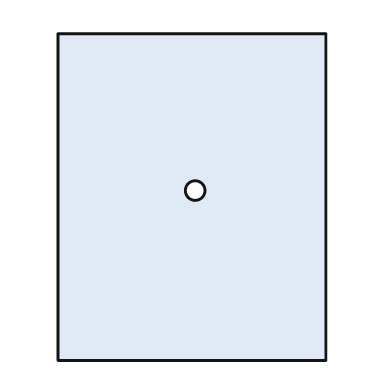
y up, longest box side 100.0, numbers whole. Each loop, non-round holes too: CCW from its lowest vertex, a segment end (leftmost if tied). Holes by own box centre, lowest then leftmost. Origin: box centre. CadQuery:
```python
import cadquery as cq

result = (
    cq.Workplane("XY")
    .moveTo(-41.0, -50.0)
    .lineTo(41.0, -50.0)
    .lineTo(41.0, 50.0)
    .lineTo(-41.0, 50.0)
    .close()
    .moveTo(1.0, 2.0)
    .circle(3.0)
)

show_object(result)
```